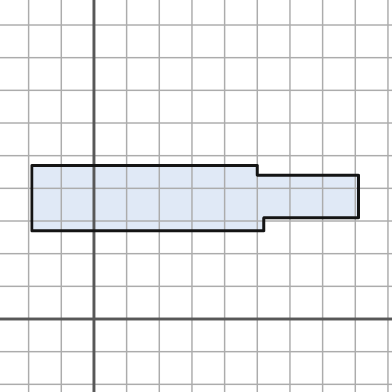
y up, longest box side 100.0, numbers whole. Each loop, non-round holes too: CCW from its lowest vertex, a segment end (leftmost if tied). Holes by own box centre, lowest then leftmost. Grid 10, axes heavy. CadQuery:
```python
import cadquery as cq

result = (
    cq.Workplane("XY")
    .moveTo(-19.0, 27.0)
    .lineTo(52.0, 27.0)
    .lineTo(52.0, 31.0)
    .lineTo(81.0, 31.0)
    .lineTo(81.0, 44.0)
    .lineTo(50.0, 44.0)
    .lineTo(50.0, 47.0)
    .lineTo(-19.0, 47.0)
    .close()
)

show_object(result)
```